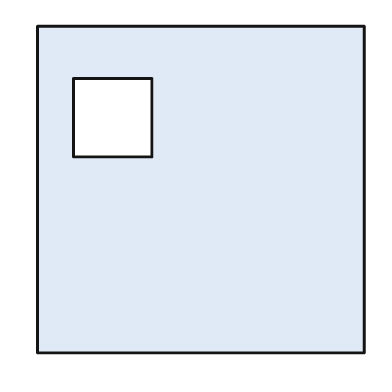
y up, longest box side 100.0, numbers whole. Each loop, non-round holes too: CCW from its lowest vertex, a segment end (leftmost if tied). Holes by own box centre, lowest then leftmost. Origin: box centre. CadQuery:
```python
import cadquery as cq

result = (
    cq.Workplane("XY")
    .moveTo(-50.0, -50.0)
    .lineTo(50.0, -50.0)
    .lineTo(50.0, 50.0)
    .lineTo(-50.0, 50.0)
    .close()
    .moveTo(-39.0, 10.0)
    .lineTo(-15.0, 10.0)
    .lineTo(-15.0, 34.0)
    .lineTo(-39.0, 34.0)
    .close()
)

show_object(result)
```